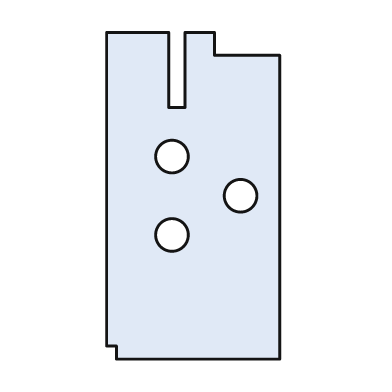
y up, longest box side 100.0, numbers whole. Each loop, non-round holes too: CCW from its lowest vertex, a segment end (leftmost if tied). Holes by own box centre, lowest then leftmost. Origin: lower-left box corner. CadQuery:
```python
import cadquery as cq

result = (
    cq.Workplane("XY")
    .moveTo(3.0, 0.0)
    .lineTo(53.0, 0.0)
    .lineTo(53.0, 93.0)
    .lineTo(33.0, 93.0)
    .lineTo(33.0, 100.0)
    .lineTo(24.0, 100.0)
    .lineTo(24.0, 77.0)
    .lineTo(19.0, 77.0)
    .lineTo(19.0, 100.0)
    .lineTo(0.0, 100.0)
    .lineTo(0.0, 4.0)
    .lineTo(3.0, 4.0)
    .close()
    .moveTo(20.0, 38.0)
    .circle(5.0)
    .moveTo(41.0, 50.0)
    .circle(5.0)
    .moveTo(20.0, 62.0)
    .circle(5.0)
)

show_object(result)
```